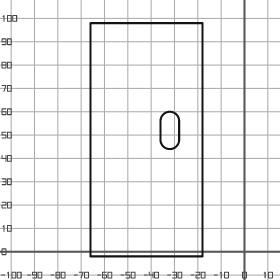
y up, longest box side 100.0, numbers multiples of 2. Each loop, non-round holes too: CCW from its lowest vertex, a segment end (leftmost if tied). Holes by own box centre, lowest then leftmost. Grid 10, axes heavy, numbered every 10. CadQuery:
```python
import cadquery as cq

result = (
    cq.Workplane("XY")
    .moveTo(-66.0, -2.0)
    .lineTo(-18.0, -2.0)
    .lineTo(-18.0, 98.0)
    .lineTo(-66.0, 98.0)
    .close()
    .moveTo(-36.0, 48.0)
    .threePointArc((-32.0, 44.0), (-28.0, 48.0))
    .lineTo(-28.0, 56.0)
    .threePointArc((-32.0, 60.0), (-36.0, 56.0))
    .close()
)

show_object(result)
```